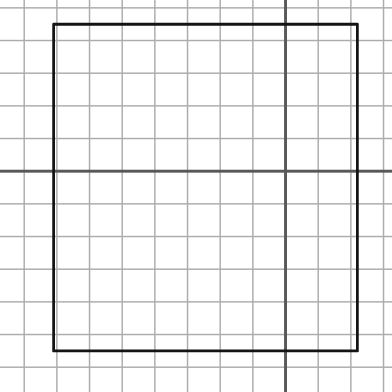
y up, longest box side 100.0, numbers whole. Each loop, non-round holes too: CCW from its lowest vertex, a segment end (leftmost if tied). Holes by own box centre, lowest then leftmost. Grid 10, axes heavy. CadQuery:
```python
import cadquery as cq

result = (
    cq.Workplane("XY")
    .moveTo(-71.0, -55.0)
    .lineTo(22.0, -55.0)
    .lineTo(22.0, 45.0)
    .lineTo(-71.0, 45.0)
    .close()
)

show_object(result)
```